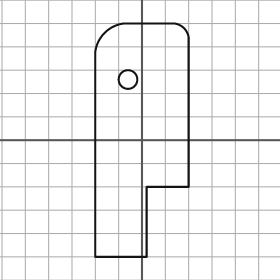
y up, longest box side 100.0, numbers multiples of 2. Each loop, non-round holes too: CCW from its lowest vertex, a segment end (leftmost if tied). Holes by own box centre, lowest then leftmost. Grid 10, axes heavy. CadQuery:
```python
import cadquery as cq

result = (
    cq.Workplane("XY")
    .moveTo(-20.0, -50.0)
    .lineTo(2.0, -50.0)
    .lineTo(2.0, -20.0)
    .lineTo(20.0, -20.0)
    .lineTo(20.0, 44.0)
    .threePointArc((18.0, 48.0), (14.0, 50.0))
    .lineTo(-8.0, 50.0)
    .threePointArc((-16.0, 46.0), (-20.0, 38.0))
    .close()
    .moveTo(-6.0, 26.0)
    .circle(4.0)
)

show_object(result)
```